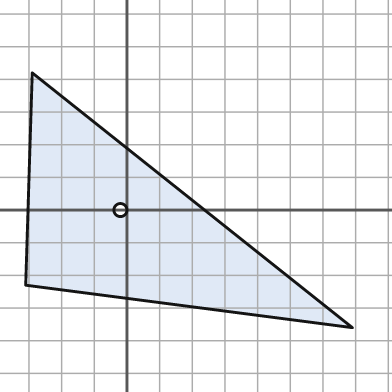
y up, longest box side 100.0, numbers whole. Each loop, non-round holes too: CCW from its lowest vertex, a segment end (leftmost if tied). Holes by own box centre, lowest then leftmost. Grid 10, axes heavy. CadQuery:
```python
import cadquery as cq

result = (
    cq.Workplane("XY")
    .moveTo(69.0, -36.0)
    .lineTo(-29.0, 42.0)
    .lineTo(-31.0, -23.0)
    .close()
    .moveTo(-2.0, 0.0)
    .circle(2.0)
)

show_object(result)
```